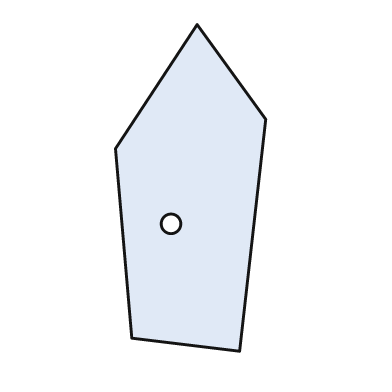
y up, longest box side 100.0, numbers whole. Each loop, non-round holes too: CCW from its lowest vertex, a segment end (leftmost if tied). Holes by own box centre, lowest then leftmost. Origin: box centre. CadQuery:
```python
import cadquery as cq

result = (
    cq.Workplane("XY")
    .moveTo(15.0, -50.0)
    .lineTo(23.0, 21.0)
    .lineTo(2.0, 50.0)
    .lineTo(-23.0, 12.0)
    .lineTo(-18.0, -46.0)
    .close()
    .moveTo(-6.0, -11.0)
    .circle(3.0)
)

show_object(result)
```